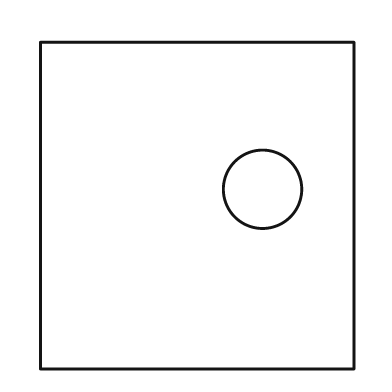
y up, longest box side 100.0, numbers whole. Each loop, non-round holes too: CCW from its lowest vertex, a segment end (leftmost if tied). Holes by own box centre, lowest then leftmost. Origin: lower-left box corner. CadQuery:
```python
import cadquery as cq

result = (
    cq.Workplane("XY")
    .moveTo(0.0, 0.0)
    .lineTo(96.0, 0.0)
    .lineTo(96.0, 100.0)
    .lineTo(0.0, 100.0)
    .close()
    .moveTo(68.0, 55.0)
    .circle(12.0)
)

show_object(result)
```